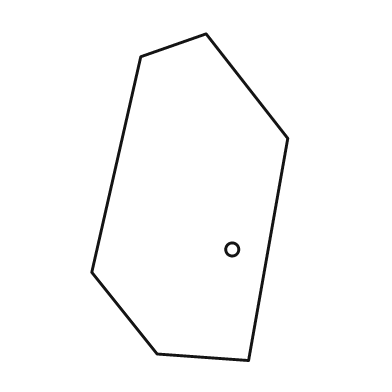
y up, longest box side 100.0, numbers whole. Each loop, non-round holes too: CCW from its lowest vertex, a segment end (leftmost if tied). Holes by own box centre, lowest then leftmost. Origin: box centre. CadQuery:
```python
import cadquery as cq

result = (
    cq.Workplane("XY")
    .moveTo(18.0, -50.0)
    .lineTo(30.0, 18.0)
    .lineTo(5.0, 50.0)
    .lineTo(-15.0, 43.0)
    .lineTo(-30.0, -23.0)
    .lineTo(-10.0, -48.0)
    .close()
    .moveTo(13.0, -16.0)
    .circle(2.0)
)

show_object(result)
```